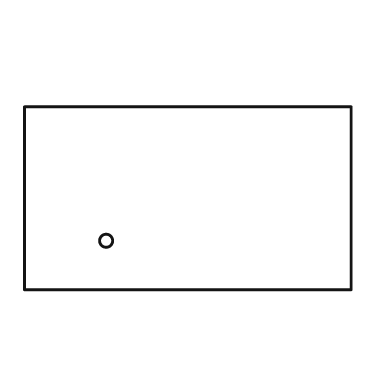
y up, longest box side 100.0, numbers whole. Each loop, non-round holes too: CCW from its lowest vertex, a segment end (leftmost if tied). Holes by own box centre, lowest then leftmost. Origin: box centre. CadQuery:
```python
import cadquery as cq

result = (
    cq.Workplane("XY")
    .moveTo(-50.0, -28.0)
    .lineTo(50.0, -28.0)
    .lineTo(50.0, 28.0)
    .lineTo(-50.0, 28.0)
    .close()
    .moveTo(-25.0, -13.0)
    .circle(2.0)
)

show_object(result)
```